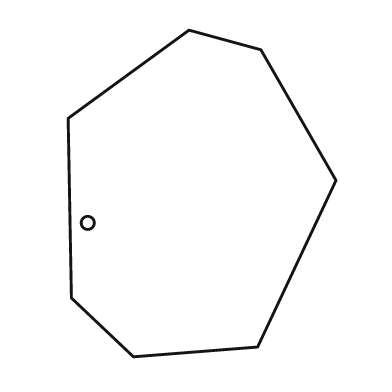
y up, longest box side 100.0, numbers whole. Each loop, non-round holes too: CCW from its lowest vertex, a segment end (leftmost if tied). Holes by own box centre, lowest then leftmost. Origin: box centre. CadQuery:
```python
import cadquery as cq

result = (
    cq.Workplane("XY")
    .moveTo(-21.0, -50.0)
    .lineTo(17.0, -47.0)
    .lineTo(41.0, 4.0)
    .lineTo(18.0, 44.0)
    .lineTo(-4.0, 50.0)
    .lineTo(-41.0, 23.0)
    .lineTo(-40.0, -32.0)
    .close()
    .moveTo(-35.0, -9.0)
    .circle(2.0)
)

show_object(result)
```